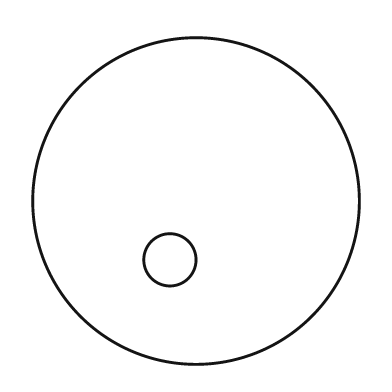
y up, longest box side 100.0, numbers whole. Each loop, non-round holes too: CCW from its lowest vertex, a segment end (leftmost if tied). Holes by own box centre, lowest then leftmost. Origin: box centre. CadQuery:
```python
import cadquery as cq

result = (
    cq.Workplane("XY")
    .moveTo(0.0, 0.0)
    .circle(50.0)
    .moveTo(-8.0, -18.0)
    .circle(8.0)
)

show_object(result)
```